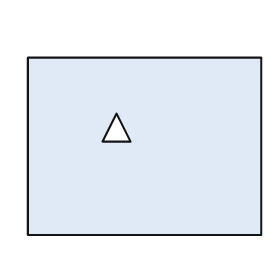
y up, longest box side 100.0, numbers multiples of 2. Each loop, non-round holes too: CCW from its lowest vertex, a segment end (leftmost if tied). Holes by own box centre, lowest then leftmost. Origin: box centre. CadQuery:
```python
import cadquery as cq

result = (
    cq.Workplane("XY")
    .moveTo(-50.0, -38.0)
    .lineTo(50.0, -38.0)
    .lineTo(50.0, 38.0)
    .lineTo(-50.0, 38.0)
    .close()
    .moveTo(-18.0, 2.0)
    .lineTo(-6.0, 2.0)
    .lineTo(-12.0, 14.0)
    .close()
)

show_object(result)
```